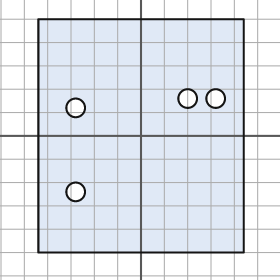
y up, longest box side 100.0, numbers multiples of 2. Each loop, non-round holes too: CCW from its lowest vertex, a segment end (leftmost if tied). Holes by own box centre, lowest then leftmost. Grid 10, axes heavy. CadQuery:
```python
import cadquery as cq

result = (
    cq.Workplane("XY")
    .moveTo(-44.0, -50.0)
    .lineTo(44.0, -50.0)
    .lineTo(44.0, 50.0)
    .lineTo(-44.0, 50.0)
    .close()
    .moveTo(-28.0, -24.0)
    .circle(4.0)
    .moveTo(-28.0, 12.0)
    .circle(4.0)
    .moveTo(20.0, 16.0)
    .circle(4.0)
    .moveTo(32.0, 16.0)
    .circle(4.0)
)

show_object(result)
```